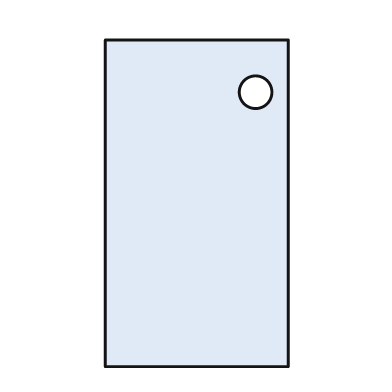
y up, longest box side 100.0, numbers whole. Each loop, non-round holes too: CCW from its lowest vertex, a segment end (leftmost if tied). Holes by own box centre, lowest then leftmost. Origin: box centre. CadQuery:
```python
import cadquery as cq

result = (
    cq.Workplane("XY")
    .moveTo(-28.0, -50.0)
    .lineTo(28.0, -50.0)
    .lineTo(28.0, 50.0)
    .lineTo(-28.0, 50.0)
    .close()
    .moveTo(18.0, 34.0)
    .circle(5.0)
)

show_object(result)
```